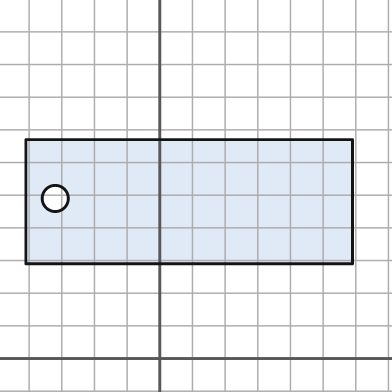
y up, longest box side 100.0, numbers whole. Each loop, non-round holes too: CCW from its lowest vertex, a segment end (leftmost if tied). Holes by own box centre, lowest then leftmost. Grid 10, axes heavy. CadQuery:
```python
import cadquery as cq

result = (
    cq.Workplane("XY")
    .moveTo(-41.0, 29.0)
    .lineTo(59.0, 29.0)
    .lineTo(59.0, 67.0)
    .lineTo(-41.0, 67.0)
    .close()
    .moveTo(-32.0, 49.0)
    .circle(4.0)
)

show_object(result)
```